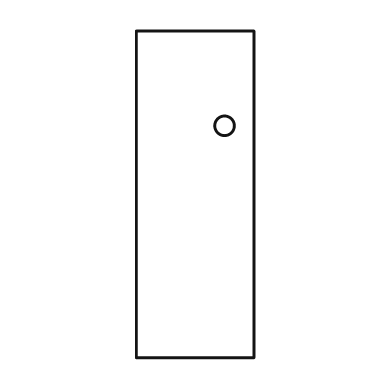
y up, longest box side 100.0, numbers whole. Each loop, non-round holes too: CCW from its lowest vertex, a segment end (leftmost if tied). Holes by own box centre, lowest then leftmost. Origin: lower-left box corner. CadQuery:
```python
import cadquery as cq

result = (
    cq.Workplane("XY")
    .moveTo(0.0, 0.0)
    .lineTo(36.0, 0.0)
    .lineTo(36.0, 100.0)
    .lineTo(0.0, 100.0)
    .close()
    .moveTo(27.0, 71.0)
    .circle(3.0)
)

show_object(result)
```